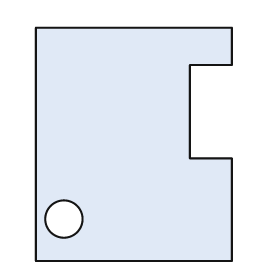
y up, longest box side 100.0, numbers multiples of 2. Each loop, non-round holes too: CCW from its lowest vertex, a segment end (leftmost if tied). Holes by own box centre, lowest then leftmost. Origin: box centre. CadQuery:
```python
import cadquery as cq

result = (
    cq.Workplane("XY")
    .moveTo(-42.0, -50.0)
    .lineTo(42.0, -50.0)
    .lineTo(42.0, -6.0)
    .lineTo(24.0, -6.0)
    .lineTo(24.0, 34.0)
    .lineTo(42.0, 34.0)
    .lineTo(42.0, 50.0)
    .lineTo(-42.0, 50.0)
    .close()
    .moveTo(-30.0, -32.0)
    .circle(8.0)
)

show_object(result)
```